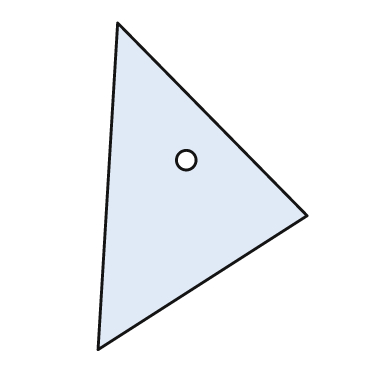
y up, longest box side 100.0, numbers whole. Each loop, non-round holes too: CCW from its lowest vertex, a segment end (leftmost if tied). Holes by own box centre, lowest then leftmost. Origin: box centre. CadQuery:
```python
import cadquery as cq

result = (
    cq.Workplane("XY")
    .moveTo(-32.0, -50.0)
    .lineTo(32.0, -9.0)
    .lineTo(-26.0, 50.0)
    .close()
    .moveTo(-5.0, 8.0)
    .circle(3.0)
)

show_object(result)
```